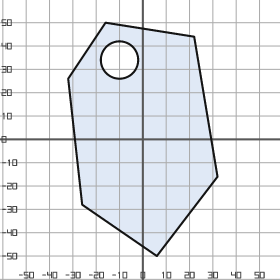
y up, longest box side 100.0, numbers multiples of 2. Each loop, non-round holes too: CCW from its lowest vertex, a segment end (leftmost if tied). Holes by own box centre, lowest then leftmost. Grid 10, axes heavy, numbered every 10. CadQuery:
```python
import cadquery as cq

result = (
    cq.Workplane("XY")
    .moveTo(6.0, -50.0)
    .lineTo(32.0, -16.0)
    .lineTo(22.0, 44.0)
    .lineTo(-16.0, 50.0)
    .lineTo(-32.0, 26.0)
    .lineTo(-26.0, -28.0)
    .close()
    .moveTo(-10.0, 34.0)
    .circle(8.0)
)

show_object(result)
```